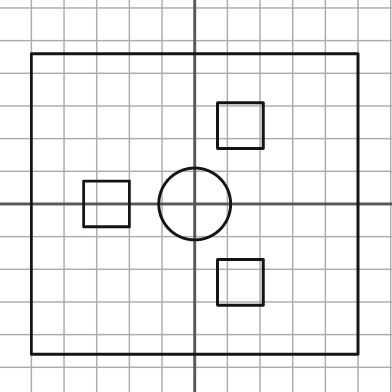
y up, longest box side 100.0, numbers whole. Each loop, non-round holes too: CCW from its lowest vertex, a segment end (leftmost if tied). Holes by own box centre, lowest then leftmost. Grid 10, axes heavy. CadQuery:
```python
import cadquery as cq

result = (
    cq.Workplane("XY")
    .moveTo(-50.0, -46.0)
    .lineTo(50.0, -46.0)
    .lineTo(50.0, 46.0)
    .lineTo(-50.0, 46.0)
    .close()
    .moveTo(7.0, -31.0)
    .lineTo(21.0, -31.0)
    .lineTo(21.0, -17.0)
    .lineTo(7.0, -17.0)
    .close()
    .moveTo(-34.0, -7.0)
    .lineTo(-20.0, -7.0)
    .lineTo(-20.0, 7.0)
    .lineTo(-34.0, 7.0)
    .close()
    .moveTo(0.0, 0.0)
    .circle(11.0)
    .moveTo(7.0, 17.0)
    .lineTo(21.0, 17.0)
    .lineTo(21.0, 31.0)
    .lineTo(7.0, 31.0)
    .close()
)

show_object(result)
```